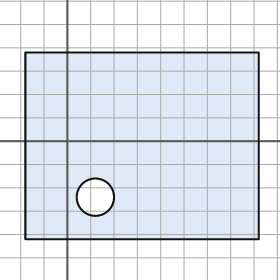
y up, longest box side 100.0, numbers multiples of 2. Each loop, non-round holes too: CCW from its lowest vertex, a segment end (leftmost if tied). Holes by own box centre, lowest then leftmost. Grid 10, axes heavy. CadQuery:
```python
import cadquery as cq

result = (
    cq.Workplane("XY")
    .moveTo(-18.0, -42.0)
    .lineTo(82.0, -42.0)
    .lineTo(82.0, 38.0)
    .lineTo(-18.0, 38.0)
    .close()
    .moveTo(12.0, -24.0)
    .circle(8.0)
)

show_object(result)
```